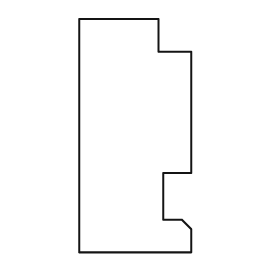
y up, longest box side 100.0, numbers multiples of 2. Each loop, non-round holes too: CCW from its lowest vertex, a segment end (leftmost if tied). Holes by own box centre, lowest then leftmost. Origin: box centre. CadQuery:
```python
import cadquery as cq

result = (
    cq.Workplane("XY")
    .moveTo(-24.0, -50.0)
    .lineTo(24.0, -50.0)
    .lineTo(24.0, -40.0)
    .lineTo(20.0, -36.0)
    .lineTo(12.0, -36.0)
    .lineTo(12.0, -16.0)
    .lineTo(24.0, -16.0)
    .lineTo(24.0, 36.0)
    .lineTo(10.0, 36.0)
    .lineTo(10.0, 50.0)
    .lineTo(-24.0, 50.0)
    .close()
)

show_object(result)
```